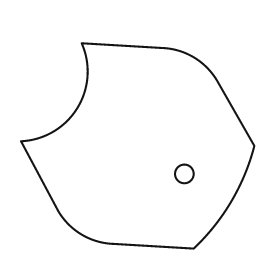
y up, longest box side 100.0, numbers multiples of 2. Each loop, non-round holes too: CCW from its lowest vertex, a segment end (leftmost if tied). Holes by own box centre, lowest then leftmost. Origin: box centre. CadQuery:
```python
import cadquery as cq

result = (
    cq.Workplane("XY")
    .moveTo(24.0, -44.0)
    .threePointArc((40.0, -24.0), (50.0, 0.0))
    .lineTo(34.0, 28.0)
    .threePointArc((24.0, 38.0), (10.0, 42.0))
    .lineTo(-24.0, 44.0)
    .threePointArc((-26.0, 16.0), (-50.0, 2.0))
    .lineTo(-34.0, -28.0)
    .threePointArc((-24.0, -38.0), (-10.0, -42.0))
    .close()
    .moveTo(20.0, -12.0)
    .circle(4.0)
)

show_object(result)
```